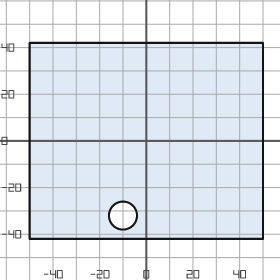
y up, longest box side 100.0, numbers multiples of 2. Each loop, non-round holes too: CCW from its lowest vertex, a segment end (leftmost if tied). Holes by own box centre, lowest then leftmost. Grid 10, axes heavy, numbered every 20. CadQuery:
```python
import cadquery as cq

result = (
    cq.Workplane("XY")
    .moveTo(-50.0, -42.0)
    .lineTo(50.0, -42.0)
    .lineTo(50.0, 42.0)
    .lineTo(-50.0, 42.0)
    .close()
    .moveTo(-10.0, -32.0)
    .circle(6.0)
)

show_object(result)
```